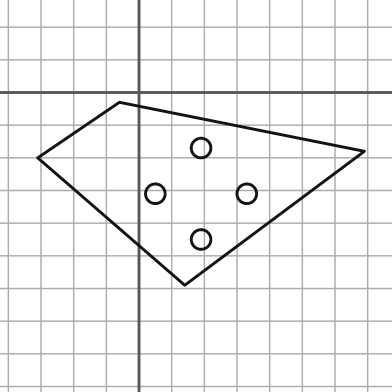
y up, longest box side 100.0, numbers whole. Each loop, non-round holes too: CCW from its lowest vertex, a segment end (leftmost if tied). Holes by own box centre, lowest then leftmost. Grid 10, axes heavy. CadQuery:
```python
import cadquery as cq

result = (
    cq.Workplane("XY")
    .moveTo(14.0, -59.0)
    .lineTo(69.0, -18.0)
    .lineTo(-6.0, -3.0)
    .lineTo(-31.0, -20.0)
    .close()
    .moveTo(19.0, -45.0)
    .circle(3.0)
    .moveTo(5.0, -31.0)
    .circle(3.0)
    .moveTo(33.0, -31.0)
    .circle(3.0)
    .moveTo(19.0, -17.0)
    .circle(3.0)
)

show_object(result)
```